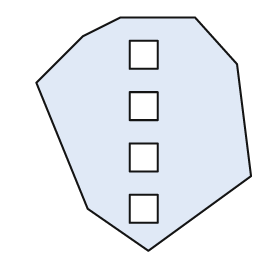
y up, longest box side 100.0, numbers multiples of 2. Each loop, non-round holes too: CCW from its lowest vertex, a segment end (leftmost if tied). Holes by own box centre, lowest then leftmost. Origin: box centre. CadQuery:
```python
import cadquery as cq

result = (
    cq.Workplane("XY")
    .moveTo(2.0, -50.0)
    .lineTo(46.0, -18.0)
    .lineTo(40.0, 30.0)
    .lineTo(22.0, 50.0)
    .lineTo(-10.0, 50.0)
    .lineTo(-26.0, 42.0)
    .lineTo(-46.0, 22.0)
    .lineTo(-24.0, -32.0)
    .close()
    .moveTo(-6.0, -38.0)
    .lineTo(6.0, -38.0)
    .lineTo(6.0, -26.0)
    .lineTo(-6.0, -26.0)
    .close()
    .moveTo(-6.0, -16.0)
    .lineTo(6.0, -16.0)
    .lineTo(6.0, -4.0)
    .lineTo(-6.0, -4.0)
    .close()
    .moveTo(-6.0, 6.0)
    .lineTo(6.0, 6.0)
    .lineTo(6.0, 18.0)
    .lineTo(-6.0, 18.0)
    .close()
    .moveTo(-6.0, 28.0)
    .lineTo(6.0, 28.0)
    .lineTo(6.0, 40.0)
    .lineTo(-6.0, 40.0)
    .close()
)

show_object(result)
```